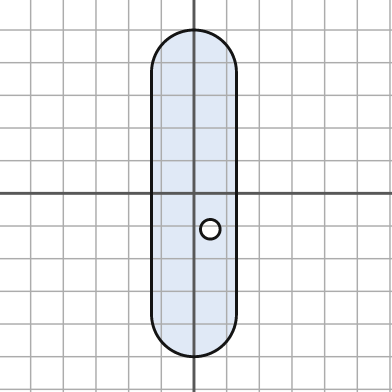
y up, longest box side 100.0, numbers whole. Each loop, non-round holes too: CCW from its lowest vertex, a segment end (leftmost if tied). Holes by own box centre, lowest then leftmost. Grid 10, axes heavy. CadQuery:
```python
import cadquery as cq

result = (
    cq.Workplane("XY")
    .moveTo(-13.0, -37.0)
    .threePointArc((0.0, -50.0), (13.0, -37.0))
    .lineTo(13.0, 37.0)
    .threePointArc((0.0, 50.0), (-13.0, 37.0))
    .close()
    .moveTo(5.0, -11.0)
    .circle(3.0)
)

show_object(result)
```